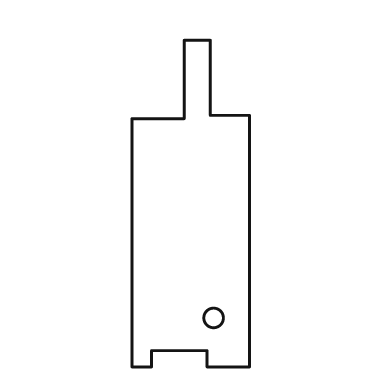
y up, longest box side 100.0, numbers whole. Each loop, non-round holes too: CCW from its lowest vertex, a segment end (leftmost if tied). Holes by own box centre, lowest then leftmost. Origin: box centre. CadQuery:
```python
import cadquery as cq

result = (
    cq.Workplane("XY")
    .moveTo(-18.0, -50.0)
    .lineTo(-12.0, -50.0)
    .lineTo(-12.0, -45.0)
    .lineTo(5.0, -45.0)
    .lineTo(5.0, -50.0)
    .lineTo(18.0, -50.0)
    .lineTo(18.0, 27.0)
    .lineTo(6.0, 27.0)
    .lineTo(6.0, 50.0)
    .lineTo(-2.0, 50.0)
    .lineTo(-2.0, 26.0)
    .lineTo(-18.0, 26.0)
    .close()
    .moveTo(7.0, -35.0)
    .circle(3.0)
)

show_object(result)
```